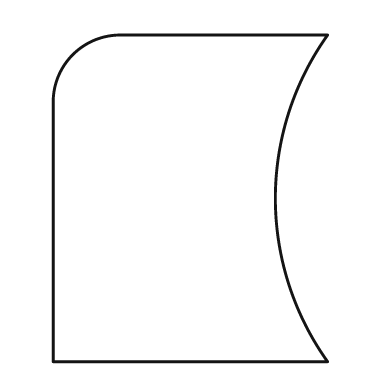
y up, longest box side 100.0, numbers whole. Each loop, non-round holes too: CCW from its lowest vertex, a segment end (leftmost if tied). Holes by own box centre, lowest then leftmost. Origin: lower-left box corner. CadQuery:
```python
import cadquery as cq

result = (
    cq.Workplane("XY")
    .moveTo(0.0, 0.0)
    .lineTo(84.0, 0.0)
    .threePointArc((68.0, 50.0), (84.0, 100.0))
    .lineTo(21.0, 100.0)
    .threePointArc((6.0, 94.0), (0.0, 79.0))
    .close()
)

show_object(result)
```